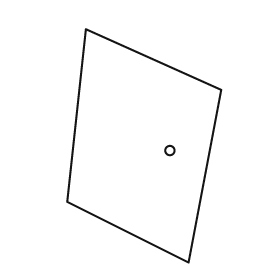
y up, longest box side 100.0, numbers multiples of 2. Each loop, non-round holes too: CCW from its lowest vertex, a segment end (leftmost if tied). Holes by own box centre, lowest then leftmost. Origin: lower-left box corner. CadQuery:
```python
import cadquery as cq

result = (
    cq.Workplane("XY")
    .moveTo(52.0, 0.0)
    .lineTo(66.0, 74.0)
    .lineTo(8.0, 100.0)
    .lineTo(0.0, 26.0)
    .close()
    .moveTo(44.0, 48.0)
    .circle(2.0)
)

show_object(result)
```